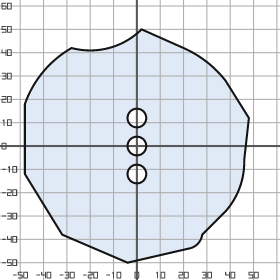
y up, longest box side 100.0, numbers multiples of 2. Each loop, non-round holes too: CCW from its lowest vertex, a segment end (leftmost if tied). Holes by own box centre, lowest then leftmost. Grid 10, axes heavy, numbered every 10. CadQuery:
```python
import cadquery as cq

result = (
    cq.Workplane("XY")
    .moveTo(-4.0, -50.0)
    .lineTo(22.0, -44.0)
    .threePointArc((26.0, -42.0), (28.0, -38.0))
    .lineTo(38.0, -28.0)
    .threePointArc((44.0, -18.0), (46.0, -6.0))
    .lineTo(48.0, 12.0)
    .lineTo(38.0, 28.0)
    .threePointArc((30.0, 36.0), (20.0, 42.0))
    .lineTo(2.0, 50.0)
    .threePointArc((-12.0, 42.0), (-28.0, 42.0))
    .threePointArc((-40.0, 32.0), (-48.0, 18.0))
    .lineTo(-48.0, -12.0)
    .lineTo(-32.0, -38.0)
    .close()
    .moveTo(0.0, -12.0)
    .circle(4.0)
    .moveTo(0.0, 0.0)
    .circle(4.0)
    .moveTo(0.0, 12.0)
    .circle(4.0)
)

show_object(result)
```